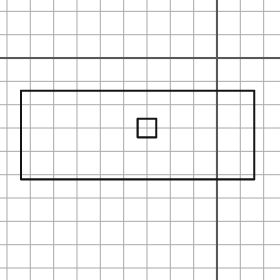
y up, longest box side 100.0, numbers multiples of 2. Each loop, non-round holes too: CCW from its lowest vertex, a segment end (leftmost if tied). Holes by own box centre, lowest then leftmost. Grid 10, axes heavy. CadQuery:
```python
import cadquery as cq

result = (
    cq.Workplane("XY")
    .moveTo(-84.0, -52.0)
    .lineTo(16.0, -52.0)
    .lineTo(16.0, -14.0)
    .lineTo(-84.0, -14.0)
    .close()
    .moveTo(-34.0, -34.0)
    .lineTo(-26.0, -34.0)
    .lineTo(-26.0, -26.0)
    .lineTo(-34.0, -26.0)
    .close()
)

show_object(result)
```